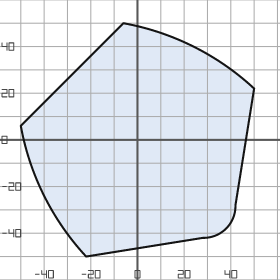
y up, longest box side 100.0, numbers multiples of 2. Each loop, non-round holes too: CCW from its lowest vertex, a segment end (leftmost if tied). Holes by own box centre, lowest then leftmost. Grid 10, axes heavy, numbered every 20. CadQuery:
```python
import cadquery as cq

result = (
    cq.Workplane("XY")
    .moveTo(-22.0, -50.0)
    .lineTo(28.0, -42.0)
    .threePointArc((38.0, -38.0), (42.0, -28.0))
    .lineTo(50.0, 22.0)
    .threePointArc((24.0, 40.0), (-6.0, 50.0))
    .lineTo(-50.0, 6.0)
    .threePointArc((-40.0, -24.0), (-22.0, -50.0))
    .close()
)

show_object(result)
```